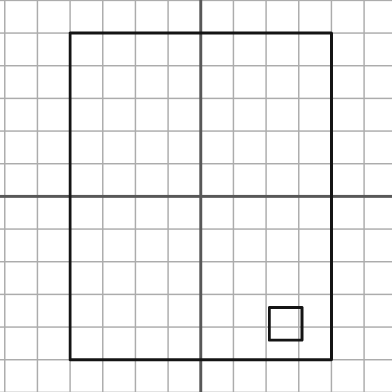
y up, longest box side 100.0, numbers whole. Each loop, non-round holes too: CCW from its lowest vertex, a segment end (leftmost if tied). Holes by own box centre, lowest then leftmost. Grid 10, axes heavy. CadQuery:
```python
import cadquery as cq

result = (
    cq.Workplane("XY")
    .moveTo(-40.0, -50.0)
    .lineTo(40.0, -50.0)
    .lineTo(40.0, 50.0)
    .lineTo(-40.0, 50.0)
    .close()
    .moveTo(21.0, -44.0)
    .lineTo(31.0, -44.0)
    .lineTo(31.0, -34.0)
    .lineTo(21.0, -34.0)
    .close()
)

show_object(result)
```